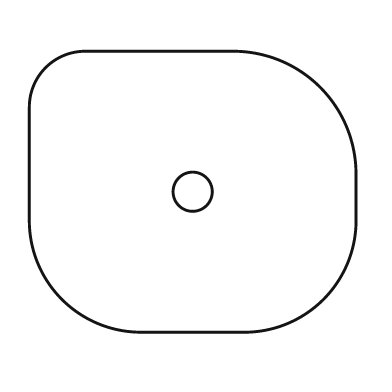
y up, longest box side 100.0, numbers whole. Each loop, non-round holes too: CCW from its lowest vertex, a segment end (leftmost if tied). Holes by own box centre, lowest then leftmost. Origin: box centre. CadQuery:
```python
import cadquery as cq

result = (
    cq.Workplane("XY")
    .moveTo(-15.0, -43.0)
    .lineTo(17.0, -43.0)
    .threePointArc((40.0, -33.0), (50.0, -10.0))
    .lineTo(50.0, 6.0)
    .threePointArc((39.0, 32.0), (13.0, 43.0))
    .lineTo(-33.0, 43.0)
    .threePointArc((-45.0, 38.0), (-50.0, 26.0))
    .lineTo(-50.0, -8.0)
    .threePointArc((-40.0, -33.0), (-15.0, -43.0))
    .close()
    .moveTo(0.0, 0.0)
    .circle(6.0)
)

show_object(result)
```